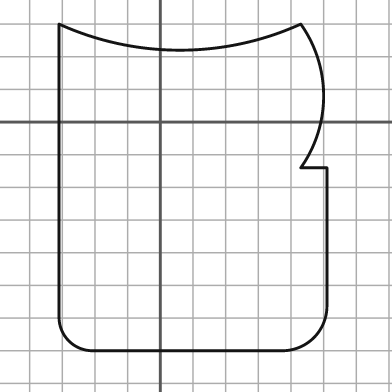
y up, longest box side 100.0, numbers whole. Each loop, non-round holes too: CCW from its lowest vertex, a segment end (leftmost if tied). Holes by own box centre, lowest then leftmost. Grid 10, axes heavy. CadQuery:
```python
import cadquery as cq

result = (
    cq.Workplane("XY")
    .moveTo(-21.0, -70.0)
    .lineTo(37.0, -70.0)
    .threePointArc((47.0, -66.0), (51.0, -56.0))
    .lineTo(51.0, -14.0)
    .lineTo(43.0, -14.0)
    .threePointArc((50.0, 8.0), (43.0, 30.0))
    .threePointArc((6.0, 22.0), (-31.0, 30.0))
    .lineTo(-31.0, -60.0)
    .threePointArc((-28.0, -67.0), (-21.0, -70.0))
    .close()
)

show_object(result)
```